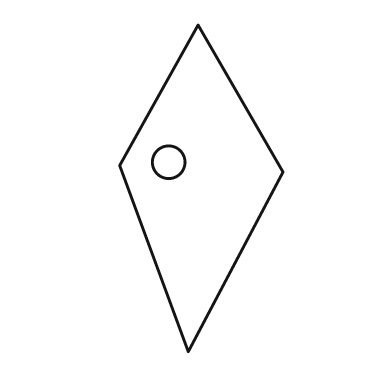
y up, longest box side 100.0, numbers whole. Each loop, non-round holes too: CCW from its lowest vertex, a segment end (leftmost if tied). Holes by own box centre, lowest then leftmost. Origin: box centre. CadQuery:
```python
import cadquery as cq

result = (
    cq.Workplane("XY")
    .moveTo(-4.0, -50.0)
    .lineTo(25.0, 5.0)
    .lineTo(-1.0, 50.0)
    .lineTo(-25.0, 7.0)
    .close()
    .moveTo(-10.0, 8.0)
    .circle(5.0)
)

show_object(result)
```